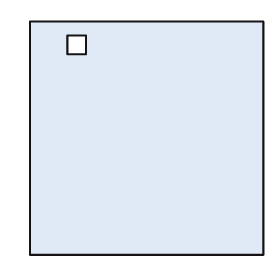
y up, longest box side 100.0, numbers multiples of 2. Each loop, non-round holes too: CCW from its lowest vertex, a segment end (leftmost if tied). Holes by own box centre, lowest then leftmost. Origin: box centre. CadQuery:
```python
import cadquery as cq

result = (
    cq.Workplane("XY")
    .moveTo(-50.0, -50.0)
    .lineTo(50.0, -50.0)
    .lineTo(50.0, 50.0)
    .lineTo(-50.0, 50.0)
    .close()
    .moveTo(-34.0, 36.0)
    .lineTo(-26.0, 36.0)
    .lineTo(-26.0, 44.0)
    .lineTo(-34.0, 44.0)
    .close()
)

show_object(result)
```